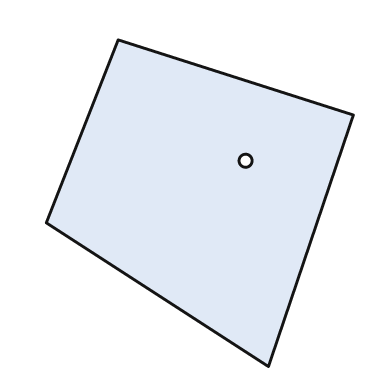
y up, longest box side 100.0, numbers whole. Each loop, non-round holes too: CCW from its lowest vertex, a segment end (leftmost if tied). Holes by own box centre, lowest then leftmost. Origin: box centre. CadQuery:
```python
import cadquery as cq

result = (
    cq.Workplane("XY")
    .moveTo(21.0, -50.0)
    .lineTo(47.0, 27.0)
    .lineTo(-25.0, 50.0)
    .lineTo(-47.0, -6.0)
    .close()
    .moveTo(14.0, 13.0)
    .circle(2.0)
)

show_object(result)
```